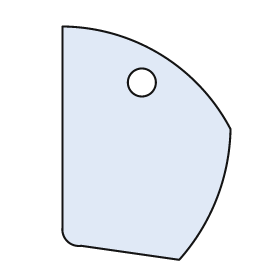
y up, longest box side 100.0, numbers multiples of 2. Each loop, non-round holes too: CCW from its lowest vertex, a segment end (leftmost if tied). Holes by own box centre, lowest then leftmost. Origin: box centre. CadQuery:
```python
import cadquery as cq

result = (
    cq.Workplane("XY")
    .moveTo(14.0, -50.0)
    .threePointArc((30.0, -24.0), (36.0, 6.0))
    .threePointArc((6.0, 38.0), (-36.0, 50.0))
    .lineTo(-36.0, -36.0)
    .threePointArc((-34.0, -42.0), (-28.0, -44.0))
    .close()
    .moveTo(-2.0, 26.0)
    .circle(6.0)
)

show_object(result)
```